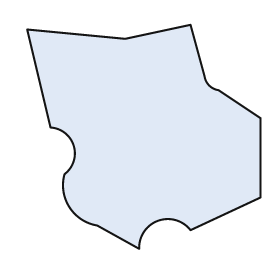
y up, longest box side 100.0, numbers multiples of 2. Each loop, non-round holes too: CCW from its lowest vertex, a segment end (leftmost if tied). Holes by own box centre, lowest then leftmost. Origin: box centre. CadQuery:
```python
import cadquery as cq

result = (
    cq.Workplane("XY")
    .moveTo(-2.0, -48.0)
    .threePointArc((6.0, -36.0), (20.0, -40.0))
    .lineTo(50.0, -26.0)
    .lineTo(50.0, 8.0)
    .lineTo(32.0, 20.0)
    .threePointArc((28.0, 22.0), (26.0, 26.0))
    .lineTo(20.0, 48.0)
    .lineTo(-8.0, 42.0)
    .lineTo(-50.0, 46.0)
    .lineTo(-40.0, 4.0)
    .threePointArc((-30.0, -4.0), (-34.0, -16.0))
    .threePointArc((-32.0, -30.0), (-20.0, -38.0))
    .close()
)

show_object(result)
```